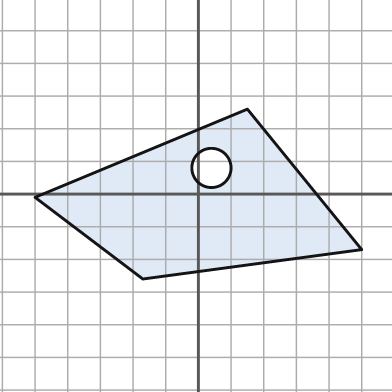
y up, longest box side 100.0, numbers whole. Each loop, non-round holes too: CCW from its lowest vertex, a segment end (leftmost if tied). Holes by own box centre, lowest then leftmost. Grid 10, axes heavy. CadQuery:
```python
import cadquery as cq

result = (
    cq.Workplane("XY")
    .moveTo(-17.0, -26.0)
    .lineTo(50.0, -17.0)
    .lineTo(15.0, 26.0)
    .lineTo(-50.0, -1.0)
    .close()
    .moveTo(4.0, 8.0)
    .circle(6.0)
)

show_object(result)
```